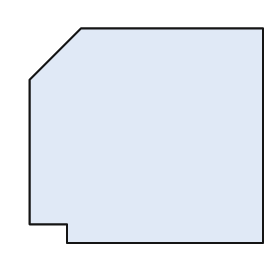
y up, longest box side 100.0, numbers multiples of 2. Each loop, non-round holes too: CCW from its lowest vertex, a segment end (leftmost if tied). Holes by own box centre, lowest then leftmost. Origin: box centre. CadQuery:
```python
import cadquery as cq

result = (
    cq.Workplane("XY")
    .moveTo(-34.0, -46.0)
    .lineTo(50.0, -46.0)
    .lineTo(50.0, 46.0)
    .lineTo(-28.0, 46.0)
    .lineTo(-50.0, 24.0)
    .lineTo(-50.0, -38.0)
    .lineTo(-34.0, -38.0)
    .close()
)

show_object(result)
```